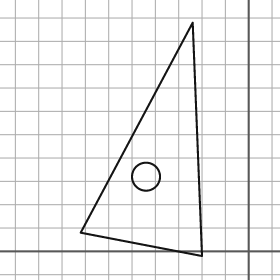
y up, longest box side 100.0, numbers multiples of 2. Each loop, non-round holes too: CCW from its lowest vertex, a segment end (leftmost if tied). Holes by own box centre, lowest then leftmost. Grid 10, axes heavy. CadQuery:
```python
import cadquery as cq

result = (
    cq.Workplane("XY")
    .moveTo(-20.0, -2.0)
    .lineTo(-24.0, 98.0)
    .lineTo(-72.0, 8.0)
    .close()
    .moveTo(-44.0, 32.0)
    .circle(6.0)
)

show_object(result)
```